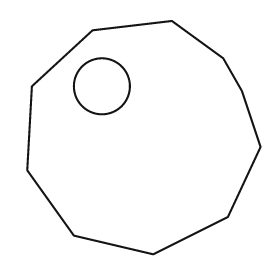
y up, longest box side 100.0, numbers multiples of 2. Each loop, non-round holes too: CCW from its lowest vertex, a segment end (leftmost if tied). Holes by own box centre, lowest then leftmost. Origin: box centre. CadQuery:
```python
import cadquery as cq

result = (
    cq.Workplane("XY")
    .moveTo(4.0, -50.0)
    .lineTo(36.0, -34.0)
    .lineTo(50.0, -4.0)
    .lineTo(42.0, 20.0)
    .lineTo(34.0, 34.0)
    .lineTo(12.0, 50.0)
    .lineTo(-22.0, 46.0)
    .lineTo(-48.0, 22.0)
    .lineTo(-50.0, -14.0)
    .lineTo(-30.0, -42.0)
    .close()
    .moveTo(-18.0, 22.0)
    .circle(12.0)
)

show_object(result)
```